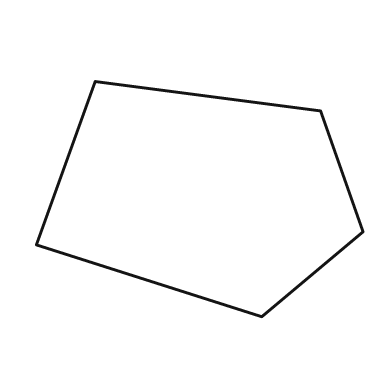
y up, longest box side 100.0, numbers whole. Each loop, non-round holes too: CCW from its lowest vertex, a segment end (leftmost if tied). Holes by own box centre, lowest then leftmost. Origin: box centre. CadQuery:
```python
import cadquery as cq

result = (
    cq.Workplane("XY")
    .moveTo(19.0, -36.0)
    .lineTo(50.0, -10.0)
    .lineTo(37.0, 27.0)
    .lineTo(-32.0, 36.0)
    .lineTo(-50.0, -14.0)
    .close()
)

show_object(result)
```